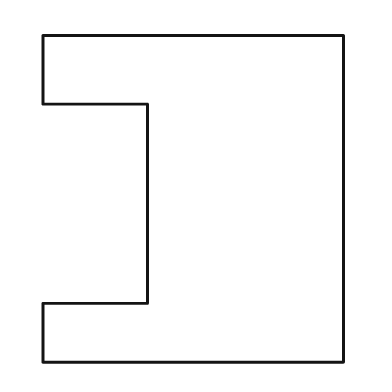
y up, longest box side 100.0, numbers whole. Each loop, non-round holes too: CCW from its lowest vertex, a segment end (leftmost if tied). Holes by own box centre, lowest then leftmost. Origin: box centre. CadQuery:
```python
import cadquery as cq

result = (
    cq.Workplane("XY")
    .moveTo(-46.0, -50.0)
    .lineTo(46.0, -50.0)
    .lineTo(46.0, 50.0)
    .lineTo(-46.0, 50.0)
    .lineTo(-46.0, 29.0)
    .lineTo(-14.0, 29.0)
    .lineTo(-14.0, -32.0)
    .lineTo(-46.0, -32.0)
    .close()
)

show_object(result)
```